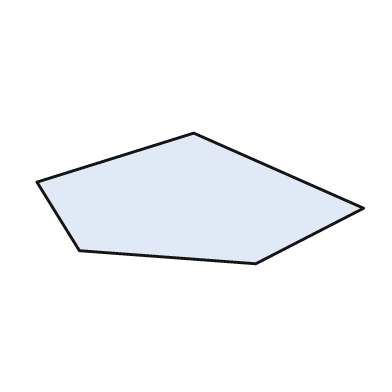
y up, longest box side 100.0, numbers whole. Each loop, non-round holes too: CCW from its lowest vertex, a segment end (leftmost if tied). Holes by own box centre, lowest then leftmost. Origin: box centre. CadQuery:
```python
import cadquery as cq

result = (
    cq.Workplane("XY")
    .moveTo(17.0, -20.0)
    .lineTo(50.0, -3.0)
    .lineTo(-2.0, 20.0)
    .lineTo(-50.0, 5.0)
    .lineTo(-37.0, -16.0)
    .close()
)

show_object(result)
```